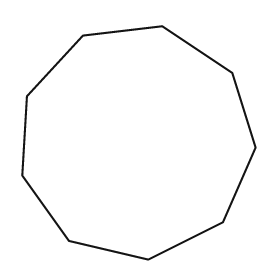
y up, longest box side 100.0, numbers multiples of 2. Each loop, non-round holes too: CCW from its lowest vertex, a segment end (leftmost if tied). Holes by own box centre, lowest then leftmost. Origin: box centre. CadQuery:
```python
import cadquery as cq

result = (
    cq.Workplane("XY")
    .moveTo(4.0, -50.0)
    .lineTo(36.0, -34.0)
    .lineTo(50.0, -2.0)
    .lineTo(40.0, 30.0)
    .lineTo(10.0, 50.0)
    .lineTo(-24.0, 46.0)
    .lineTo(-48.0, 20.0)
    .lineTo(-50.0, -14.0)
    .lineTo(-30.0, -42.0)
    .close()
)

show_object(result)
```